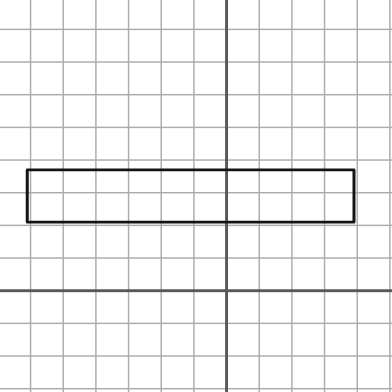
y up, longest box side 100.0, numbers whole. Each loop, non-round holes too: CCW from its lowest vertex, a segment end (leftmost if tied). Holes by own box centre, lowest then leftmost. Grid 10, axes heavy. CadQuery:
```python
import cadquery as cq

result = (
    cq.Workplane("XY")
    .moveTo(-61.0, 21.0)
    .lineTo(39.0, 21.0)
    .lineTo(39.0, 37.0)
    .lineTo(-61.0, 37.0)
    .close()
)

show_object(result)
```